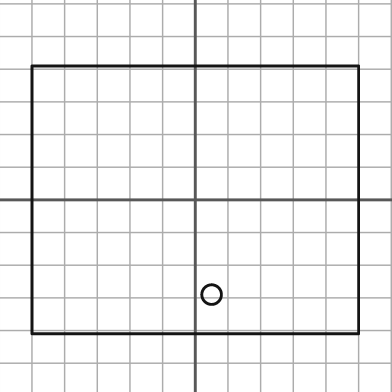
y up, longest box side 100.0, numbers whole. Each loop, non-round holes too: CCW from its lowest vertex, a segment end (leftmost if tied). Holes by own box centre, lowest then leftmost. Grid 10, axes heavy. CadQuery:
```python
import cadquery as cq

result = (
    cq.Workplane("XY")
    .moveTo(-50.0, -41.0)
    .lineTo(50.0, -41.0)
    .lineTo(50.0, 41.0)
    .lineTo(-50.0, 41.0)
    .close()
    .moveTo(5.0, -29.0)
    .circle(3.0)
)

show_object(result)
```